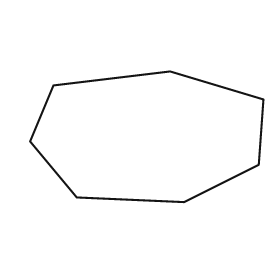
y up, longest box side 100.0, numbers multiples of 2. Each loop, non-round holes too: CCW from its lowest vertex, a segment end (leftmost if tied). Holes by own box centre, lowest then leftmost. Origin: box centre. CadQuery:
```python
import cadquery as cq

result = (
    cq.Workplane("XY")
    .moveTo(16.0, -28.0)
    .lineTo(48.0, -12.0)
    .lineTo(50.0, 16.0)
    .lineTo(10.0, 28.0)
    .lineTo(-40.0, 22.0)
    .lineTo(-50.0, -2.0)
    .lineTo(-30.0, -26.0)
    .close()
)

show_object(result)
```